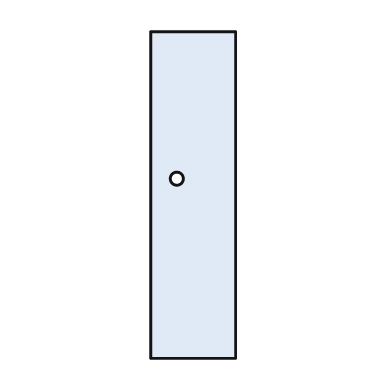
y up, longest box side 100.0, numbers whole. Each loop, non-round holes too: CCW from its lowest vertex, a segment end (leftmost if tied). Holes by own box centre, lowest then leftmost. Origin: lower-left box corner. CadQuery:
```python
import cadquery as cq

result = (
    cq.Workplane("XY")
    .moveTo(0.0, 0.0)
    .lineTo(26.0, 0.0)
    .lineTo(26.0, 100.0)
    .lineTo(0.0, 100.0)
    .close()
    .moveTo(8.0, 55.0)
    .circle(2.0)
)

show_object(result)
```